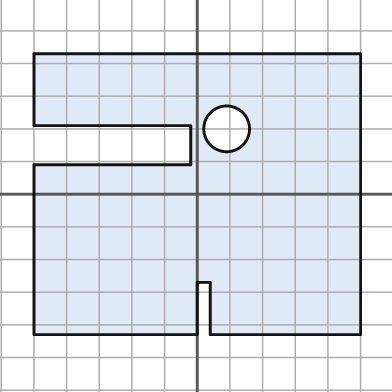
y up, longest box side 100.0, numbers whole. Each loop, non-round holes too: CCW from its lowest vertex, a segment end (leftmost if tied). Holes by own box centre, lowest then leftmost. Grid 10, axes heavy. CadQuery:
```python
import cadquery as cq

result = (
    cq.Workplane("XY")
    .moveTo(-50.0, -43.0)
    .lineTo(0.0, -43.0)
    .lineTo(0.0, -27.0)
    .lineTo(4.0, -27.0)
    .lineTo(4.0, -43.0)
    .lineTo(50.0, -43.0)
    .lineTo(50.0, 43.0)
    .lineTo(-50.0, 43.0)
    .lineTo(-50.0, 21.0)
    .lineTo(-2.0, 21.0)
    .lineTo(-2.0, 9.0)
    .lineTo(-50.0, 9.0)
    .close()
    .moveTo(9.0, 20.0)
    .circle(7.0)
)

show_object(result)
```